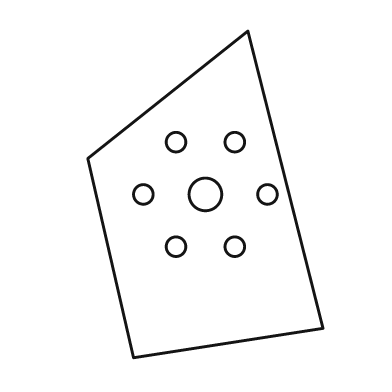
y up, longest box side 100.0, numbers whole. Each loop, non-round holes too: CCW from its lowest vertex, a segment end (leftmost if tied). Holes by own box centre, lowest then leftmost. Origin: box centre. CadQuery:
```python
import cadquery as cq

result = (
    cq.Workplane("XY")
    .moveTo(-22.0, -50.0)
    .lineTo(36.0, -41.0)
    .lineTo(13.0, 50.0)
    .lineTo(-36.0, 11.0)
    .close()
    .moveTo(-9.0, -16.0)
    .circle(3.0)
    .moveTo(9.0, -16.0)
    .circle(3.0)
    .moveTo(-19.0, 0.0)
    .circle(3.0)
    .moveTo(0.0, 0.0)
    .circle(5.0)
    .moveTo(19.0, 0.0)
    .circle(3.0)
    .moveTo(-9.0, 16.0)
    .circle(3.0)
    .moveTo(9.0, 16.0)
    .circle(3.0)
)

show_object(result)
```